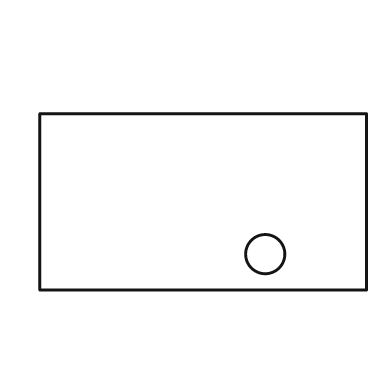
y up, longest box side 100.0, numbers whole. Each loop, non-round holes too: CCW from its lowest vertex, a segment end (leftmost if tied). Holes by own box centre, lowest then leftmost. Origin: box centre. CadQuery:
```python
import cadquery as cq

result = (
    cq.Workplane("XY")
    .moveTo(-50.0, -27.0)
    .lineTo(50.0, -27.0)
    .lineTo(50.0, 27.0)
    .lineTo(-50.0, 27.0)
    .close()
    .moveTo(19.0, -16.0)
    .circle(6.0)
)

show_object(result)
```